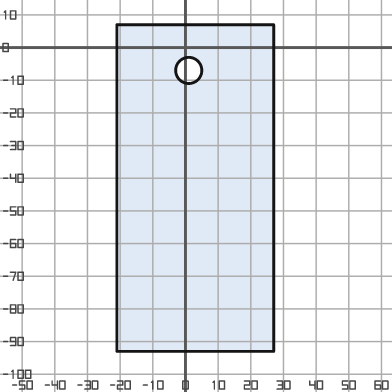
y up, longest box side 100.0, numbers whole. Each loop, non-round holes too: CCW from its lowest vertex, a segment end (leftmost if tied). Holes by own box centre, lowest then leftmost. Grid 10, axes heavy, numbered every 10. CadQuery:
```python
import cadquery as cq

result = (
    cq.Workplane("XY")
    .moveTo(-21.0, -93.0)
    .lineTo(27.0, -93.0)
    .lineTo(27.0, 7.0)
    .lineTo(-21.0, 7.0)
    .close()
    .moveTo(1.0, -7.0)
    .circle(4.0)
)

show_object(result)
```